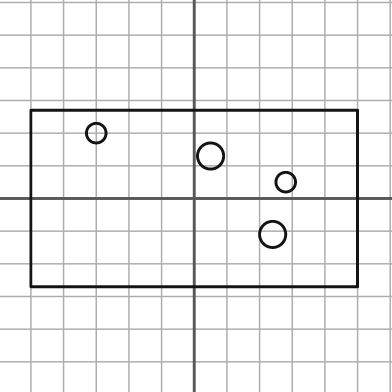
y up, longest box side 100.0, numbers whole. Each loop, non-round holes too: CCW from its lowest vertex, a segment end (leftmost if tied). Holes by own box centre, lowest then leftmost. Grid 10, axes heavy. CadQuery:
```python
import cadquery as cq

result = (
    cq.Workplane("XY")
    .moveTo(-50.0, -27.0)
    .lineTo(50.0, -27.0)
    .lineTo(50.0, 27.0)
    .lineTo(-50.0, 27.0)
    .close()
    .moveTo(24.0, -11.0)
    .circle(4.0)
    .moveTo(28.0, 5.0)
    .circle(3.0)
    .moveTo(5.0, 13.0)
    .circle(4.0)
    .moveTo(-30.0, 20.0)
    .circle(3.0)
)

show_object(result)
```